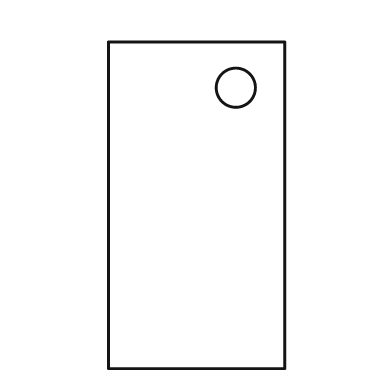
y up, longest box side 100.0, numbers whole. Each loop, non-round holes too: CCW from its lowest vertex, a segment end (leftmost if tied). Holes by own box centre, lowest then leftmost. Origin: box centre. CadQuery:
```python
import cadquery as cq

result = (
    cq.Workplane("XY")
    .moveTo(-27.0, -50.0)
    .lineTo(27.0, -50.0)
    .lineTo(27.0, 50.0)
    .lineTo(-27.0, 50.0)
    .close()
    .moveTo(12.0, 36.0)
    .circle(6.0)
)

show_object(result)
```